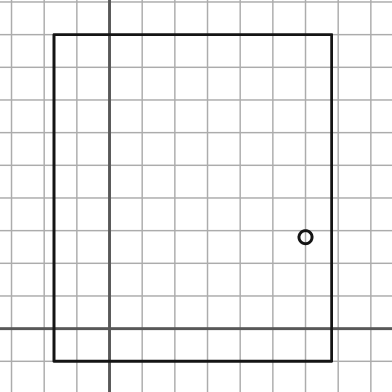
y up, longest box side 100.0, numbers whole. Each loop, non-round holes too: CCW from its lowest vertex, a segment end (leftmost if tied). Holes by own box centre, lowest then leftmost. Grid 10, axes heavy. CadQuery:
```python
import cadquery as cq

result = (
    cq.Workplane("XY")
    .moveTo(-17.0, -10.0)
    .lineTo(68.0, -10.0)
    .lineTo(68.0, 90.0)
    .lineTo(-17.0, 90.0)
    .close()
    .moveTo(60.0, 28.0)
    .circle(2.0)
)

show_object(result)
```